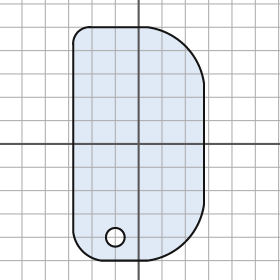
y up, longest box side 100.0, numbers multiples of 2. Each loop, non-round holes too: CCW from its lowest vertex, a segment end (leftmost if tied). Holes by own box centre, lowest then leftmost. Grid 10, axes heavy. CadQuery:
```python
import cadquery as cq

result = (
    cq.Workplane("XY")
    .moveTo(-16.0, -50.0)
    .lineTo(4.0, -50.0)
    .threePointArc((20.0, -42.0), (28.0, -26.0))
    .lineTo(28.0, 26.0)
    .threePointArc((20.0, 42.0), (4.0, 50.0))
    .lineTo(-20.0, 50.0)
    .threePointArc((-26.0, 48.0), (-28.0, 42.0))
    .lineTo(-28.0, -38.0)
    .threePointArc((-24.0, -46.0), (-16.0, -50.0))
    .close()
    .moveTo(-10.0, -40.0)
    .circle(4.0)
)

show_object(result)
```